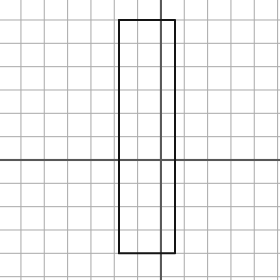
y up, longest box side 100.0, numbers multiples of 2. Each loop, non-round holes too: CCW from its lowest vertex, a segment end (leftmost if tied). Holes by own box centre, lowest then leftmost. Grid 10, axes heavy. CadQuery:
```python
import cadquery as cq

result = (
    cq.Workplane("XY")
    .moveTo(-18.0, -40.0)
    .lineTo(6.0, -40.0)
    .lineTo(6.0, 60.0)
    .lineTo(-18.0, 60.0)
    .close()
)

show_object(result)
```